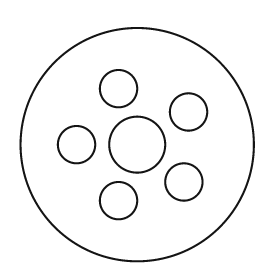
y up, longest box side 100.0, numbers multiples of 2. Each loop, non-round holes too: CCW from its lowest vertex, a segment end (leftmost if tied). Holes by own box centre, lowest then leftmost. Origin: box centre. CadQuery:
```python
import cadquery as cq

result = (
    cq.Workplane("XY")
    .moveTo(0.0, 0.0)
    .circle(50.0)
    .moveTo(-8.0, -24.0)
    .circle(8.0)
    .moveTo(20.0, -16.0)
    .circle(8.0)
    .moveTo(-26.0, 0.0)
    .circle(8.0)
    .moveTo(0.0, 0.0)
    .circle(12.0)
    .moveTo(22.0, 14.0)
    .circle(8.0)
    .moveTo(-8.0, 24.0)
    .circle(8.0)
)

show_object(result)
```